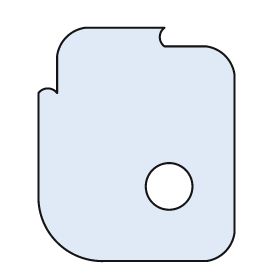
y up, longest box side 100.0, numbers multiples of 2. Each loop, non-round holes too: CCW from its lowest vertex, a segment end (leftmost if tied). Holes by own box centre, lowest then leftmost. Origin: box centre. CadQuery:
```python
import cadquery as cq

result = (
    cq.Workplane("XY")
    .moveTo(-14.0, -50.0)
    .lineTo(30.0, -50.0)
    .threePointArc((38.0, -46.0), (42.0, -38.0))
    .lineTo(42.0, 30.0)
    .threePointArc((38.0, 38.0), (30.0, 42.0))
    .lineTo(12.0, 42.0)
    .threePointArc((10.0, 46.0), (12.0, 50.0))
    .lineTo(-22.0, 50.0)
    .threePointArc((-30.0, 46.0), (-34.0, 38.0))
    .lineTo(-34.0, 22.0)
    .threePointArc((-38.0, 24.0), (-42.0, 22.0))
    .lineTo(-42.0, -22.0)
    .threePointArc((-34.0, -42.0), (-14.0, -50.0))
    .close()
    .moveTo(14.0, -18.0)
    .circle(10.0)
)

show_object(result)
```